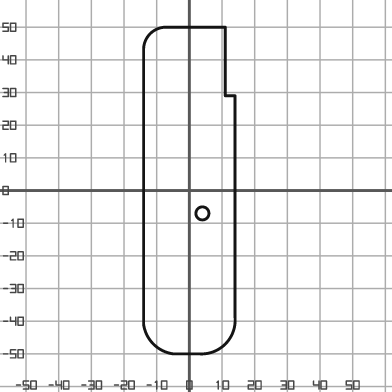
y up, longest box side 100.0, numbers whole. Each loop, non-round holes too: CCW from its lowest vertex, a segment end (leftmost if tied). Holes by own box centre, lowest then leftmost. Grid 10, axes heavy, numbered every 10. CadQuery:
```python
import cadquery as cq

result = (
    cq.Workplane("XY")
    .moveTo(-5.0, -50.0)
    .lineTo(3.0, -50.0)
    .threePointArc((11.0, -47.0), (14.0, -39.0))
    .lineTo(14.0, 29.0)
    .lineTo(11.0, 29.0)
    .lineTo(11.0, 50.0)
    .lineTo(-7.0, 50.0)
    .threePointArc((-12.0, 48.0), (-14.0, 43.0))
    .lineTo(-14.0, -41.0)
    .threePointArc((-11.0, -47.0), (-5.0, -50.0))
    .close()
    .moveTo(4.0, -7.0)
    .circle(2.0)
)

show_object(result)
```